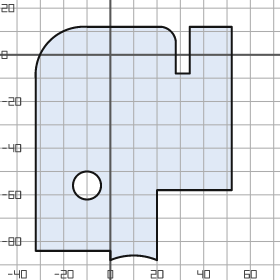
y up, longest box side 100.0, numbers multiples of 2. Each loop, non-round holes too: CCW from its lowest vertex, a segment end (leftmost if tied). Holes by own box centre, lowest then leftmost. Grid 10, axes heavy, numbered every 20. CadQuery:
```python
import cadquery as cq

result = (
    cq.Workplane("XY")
    .moveTo(0.0, -88.0)
    .threePointArc((10.0, -86.0), (20.0, -88.0))
    .lineTo(20.0, -58.0)
    .lineTo(52.0, -58.0)
    .lineTo(52.0, 12.0)
    .lineTo(34.0, 12.0)
    .lineTo(34.0, -8.0)
    .lineTo(28.0, -8.0)
    .lineTo(28.0, 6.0)
    .threePointArc((26.0, 10.0), (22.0, 12.0))
    .lineTo(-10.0, 12.0)
    .threePointArc((-26.0, 6.0), (-32.0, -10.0))
    .lineTo(-32.0, -84.0)
    .lineTo(0.0, -84.0)
    .close()
    .moveTo(-10.0, -56.0)
    .circle(6.0)
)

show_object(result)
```